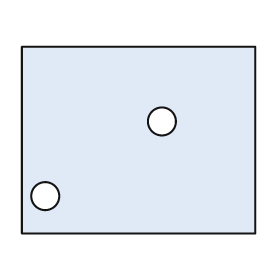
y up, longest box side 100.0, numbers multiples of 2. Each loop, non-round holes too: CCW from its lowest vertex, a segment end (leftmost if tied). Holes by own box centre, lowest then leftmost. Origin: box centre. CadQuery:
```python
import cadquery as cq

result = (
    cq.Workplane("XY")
    .moveTo(-50.0, -40.0)
    .lineTo(50.0, -40.0)
    .lineTo(50.0, 40.0)
    .lineTo(-50.0, 40.0)
    .close()
    .moveTo(-40.0, -24.0)
    .circle(6.0)
    .moveTo(10.0, 8.0)
    .circle(6.0)
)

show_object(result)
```